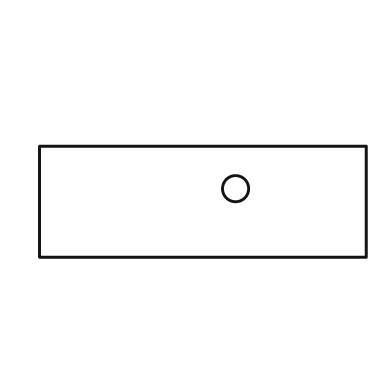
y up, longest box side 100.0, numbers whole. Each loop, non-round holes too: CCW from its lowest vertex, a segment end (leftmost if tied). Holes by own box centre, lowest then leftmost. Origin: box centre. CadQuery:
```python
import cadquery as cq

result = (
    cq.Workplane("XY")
    .moveTo(-50.0, -17.0)
    .lineTo(50.0, -17.0)
    .lineTo(50.0, 17.0)
    .lineTo(-50.0, 17.0)
    .close()
    .moveTo(10.0, 4.0)
    .circle(4.0)
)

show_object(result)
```